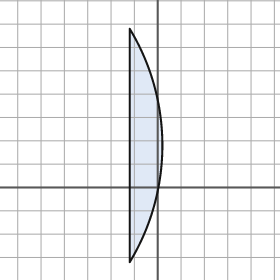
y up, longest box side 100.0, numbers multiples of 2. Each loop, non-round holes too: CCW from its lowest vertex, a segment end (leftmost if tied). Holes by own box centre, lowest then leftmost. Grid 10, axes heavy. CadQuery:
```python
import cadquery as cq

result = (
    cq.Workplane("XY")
    .moveTo(-12.0, -32.0)
    .threePointArc((2.0, 18.0), (-12.0, 68.0))
    .close()
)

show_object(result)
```